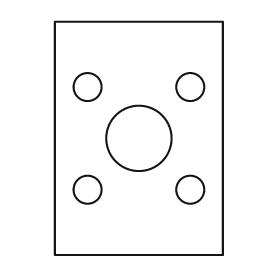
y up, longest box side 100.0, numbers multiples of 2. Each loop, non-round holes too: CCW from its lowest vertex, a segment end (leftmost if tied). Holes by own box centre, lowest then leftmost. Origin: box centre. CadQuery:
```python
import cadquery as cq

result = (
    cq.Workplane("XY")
    .moveTo(-36.0, -50.0)
    .lineTo(36.0, -50.0)
    .lineTo(36.0, 50.0)
    .lineTo(-36.0, 50.0)
    .close()
    .moveTo(-22.0, -22.0)
    .circle(6.0)
    .moveTo(22.0, -22.0)
    .circle(6.0)
    .moveTo(0.0, 0.0)
    .circle(14.0)
    .moveTo(-22.0, 22.0)
    .circle(6.0)
    .moveTo(22.0, 22.0)
    .circle(6.0)
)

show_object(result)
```